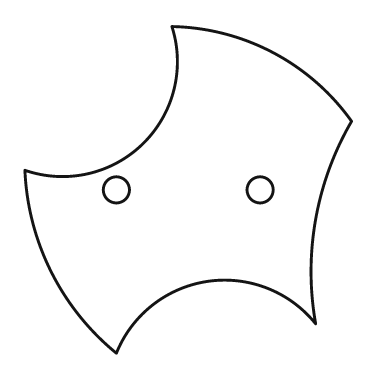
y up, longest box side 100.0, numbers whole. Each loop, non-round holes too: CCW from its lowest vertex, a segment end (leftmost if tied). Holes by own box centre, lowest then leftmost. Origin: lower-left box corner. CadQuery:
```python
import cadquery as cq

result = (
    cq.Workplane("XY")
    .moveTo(28.0, 0.0)
    .threePointArc((56.0, 22.0), (89.0, 9.0))
    .threePointArc((89.0, 41.0), (100.0, 71.0))
    .threePointArc((76.0, 92.0), (45.0, 100.0))
    .threePointArc((36.0, 64.0), (0.0, 56.0))
    .threePointArc((8.0, 25.0), (28.0, 0.0))
    .close()
    .moveTo(28.0, 50.0)
    .circle(4.0)
    .moveTo(72.0, 50.0)
    .circle(4.0)
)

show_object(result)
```